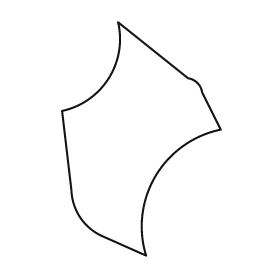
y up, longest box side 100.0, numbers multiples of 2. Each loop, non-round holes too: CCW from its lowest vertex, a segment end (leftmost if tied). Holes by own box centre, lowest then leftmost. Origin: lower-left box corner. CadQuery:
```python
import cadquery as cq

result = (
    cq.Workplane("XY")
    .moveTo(36.0, 0.0)
    .threePointArc((40.0, 34.0), (68.0, 54.0))
    .lineTo(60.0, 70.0)
    .threePointArc((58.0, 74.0), (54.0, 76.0))
    .lineTo(24.0, 100.0)
    .threePointArc((20.0, 76.0), (0.0, 62.0))
    .lineTo(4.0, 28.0)
    .threePointArc((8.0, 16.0), (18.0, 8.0))
    .close()
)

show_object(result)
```